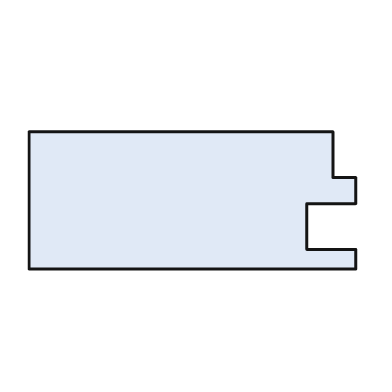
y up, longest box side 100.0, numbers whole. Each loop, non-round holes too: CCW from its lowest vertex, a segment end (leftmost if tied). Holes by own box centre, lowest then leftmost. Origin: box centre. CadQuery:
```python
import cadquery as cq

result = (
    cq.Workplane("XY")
    .moveTo(-50.0, -21.0)
    .lineTo(50.0, -21.0)
    .lineTo(50.0, -15.0)
    .lineTo(35.0, -15.0)
    .lineTo(35.0, -1.0)
    .lineTo(50.0, -1.0)
    .lineTo(50.0, 7.0)
    .lineTo(43.0, 7.0)
    .lineTo(43.0, 21.0)
    .lineTo(-50.0, 21.0)
    .close()
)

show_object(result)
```